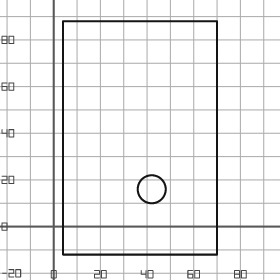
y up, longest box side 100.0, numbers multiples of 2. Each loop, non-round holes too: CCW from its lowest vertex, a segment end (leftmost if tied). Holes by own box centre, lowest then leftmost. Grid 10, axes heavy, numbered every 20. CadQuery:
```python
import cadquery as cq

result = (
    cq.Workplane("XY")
    .moveTo(4.0, -12.0)
    .lineTo(70.0, -12.0)
    .lineTo(70.0, 88.0)
    .lineTo(4.0, 88.0)
    .close()
    .moveTo(42.0, 16.0)
    .circle(6.0)
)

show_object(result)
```